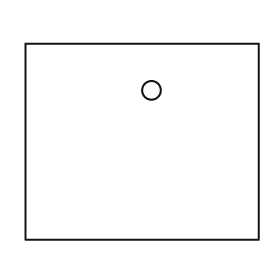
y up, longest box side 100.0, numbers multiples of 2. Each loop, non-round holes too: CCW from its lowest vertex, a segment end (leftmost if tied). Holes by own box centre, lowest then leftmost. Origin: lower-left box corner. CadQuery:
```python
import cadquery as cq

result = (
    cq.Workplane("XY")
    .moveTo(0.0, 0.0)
    .lineTo(100.0, 0.0)
    .lineTo(100.0, 84.0)
    .lineTo(0.0, 84.0)
    .close()
    .moveTo(54.0, 64.0)
    .circle(4.0)
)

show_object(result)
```